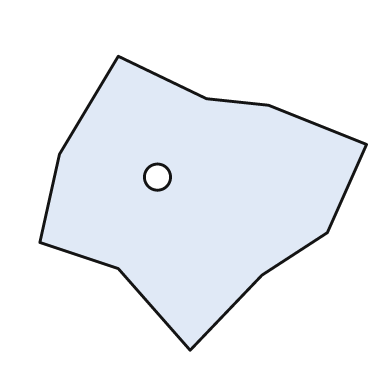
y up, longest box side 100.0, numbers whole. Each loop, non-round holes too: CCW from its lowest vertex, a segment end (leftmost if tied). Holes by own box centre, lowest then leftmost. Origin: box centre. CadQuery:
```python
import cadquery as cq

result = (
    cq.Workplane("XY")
    .moveTo(-4.0, -45.0)
    .lineTo(18.0, -22.0)
    .lineTo(38.0, -9.0)
    .lineTo(50.0, 18.0)
    .lineTo(20.0, 30.0)
    .lineTo(1.0, 32.0)
    .lineTo(-26.0, 45.0)
    .lineTo(-44.0, 15.0)
    .lineTo(-50.0, -12.0)
    .lineTo(-26.0, -20.0)
    .close()
    .moveTo(-14.0, 8.0)
    .circle(4.0)
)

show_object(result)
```